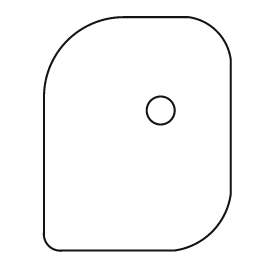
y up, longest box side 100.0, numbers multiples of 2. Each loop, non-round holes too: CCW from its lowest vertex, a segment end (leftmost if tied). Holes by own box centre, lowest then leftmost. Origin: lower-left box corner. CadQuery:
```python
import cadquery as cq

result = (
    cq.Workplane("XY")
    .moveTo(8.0, 0.0)
    .lineTo(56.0, 0.0)
    .threePointArc((72.0, 8.0), (80.0, 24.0))
    .lineTo(80.0, 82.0)
    .threePointArc((74.0, 94.0), (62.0, 100.0))
    .lineTo(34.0, 100.0)
    .threePointArc((10.0, 90.0), (0.0, 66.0))
    .lineTo(0.0, 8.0)
    .threePointArc((2.0, 2.0), (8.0, 0.0))
    .close()
    .moveTo(50.0, 60.0)
    .circle(6.0)
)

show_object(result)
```